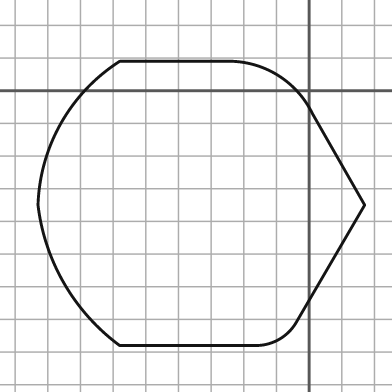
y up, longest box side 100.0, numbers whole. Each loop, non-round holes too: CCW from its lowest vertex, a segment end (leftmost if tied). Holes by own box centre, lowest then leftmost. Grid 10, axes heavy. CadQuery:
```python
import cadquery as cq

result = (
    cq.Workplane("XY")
    .moveTo(-58.0, -78.0)
    .lineTo(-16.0, -78.0)
    .threePointArc((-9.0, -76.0), (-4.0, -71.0))
    .lineTo(17.0, -35.0)
    .lineTo(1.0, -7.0)
    .threePointArc((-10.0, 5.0), (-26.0, 9.0))
    .lineTo(-58.0, 9.0)
    .threePointArc((-76.0, -10.0), (-83.0, -35.0))
    .threePointArc((-75.0, -59.0), (-58.0, -78.0))
    .close()
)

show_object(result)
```